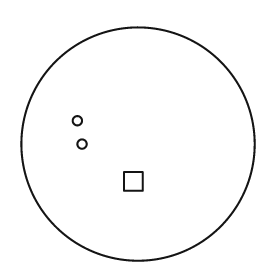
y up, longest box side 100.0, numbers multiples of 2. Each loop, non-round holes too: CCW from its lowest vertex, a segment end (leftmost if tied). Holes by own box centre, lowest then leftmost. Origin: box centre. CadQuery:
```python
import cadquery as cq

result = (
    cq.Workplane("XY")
    .moveTo(0.0, 0.0)
    .circle(50.0)
    .moveTo(-6.0, -20.0)
    .lineTo(2.0, -20.0)
    .lineTo(2.0, -12.0)
    .lineTo(-6.0, -12.0)
    .close()
    .moveTo(-24.0, 0.0)
    .circle(2.0)
    .moveTo(-26.0, 10.0)
    .circle(2.0)
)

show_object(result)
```